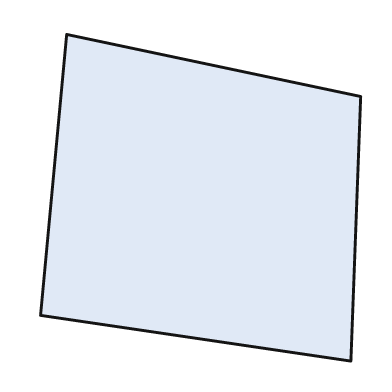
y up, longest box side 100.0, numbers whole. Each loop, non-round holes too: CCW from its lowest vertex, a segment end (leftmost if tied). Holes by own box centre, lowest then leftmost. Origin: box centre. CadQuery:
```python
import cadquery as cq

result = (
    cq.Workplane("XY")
    .moveTo(46.0, -50.0)
    .lineTo(49.0, 31.0)
    .lineTo(-41.0, 50.0)
    .lineTo(-49.0, -36.0)
    .close()
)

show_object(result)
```